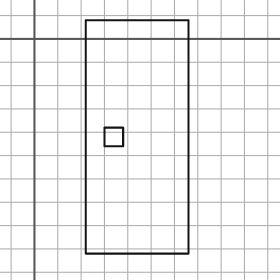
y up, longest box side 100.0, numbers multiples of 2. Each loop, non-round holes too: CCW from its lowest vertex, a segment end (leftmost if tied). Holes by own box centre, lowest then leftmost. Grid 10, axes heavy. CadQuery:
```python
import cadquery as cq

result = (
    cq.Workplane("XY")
    .moveTo(22.0, -92.0)
    .lineTo(66.0, -92.0)
    .lineTo(66.0, 8.0)
    .lineTo(22.0, 8.0)
    .close()
    .moveTo(30.0, -46.0)
    .lineTo(38.0, -46.0)
    .lineTo(38.0, -38.0)
    .lineTo(30.0, -38.0)
    .close()
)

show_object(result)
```